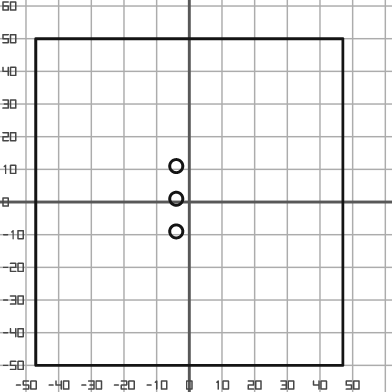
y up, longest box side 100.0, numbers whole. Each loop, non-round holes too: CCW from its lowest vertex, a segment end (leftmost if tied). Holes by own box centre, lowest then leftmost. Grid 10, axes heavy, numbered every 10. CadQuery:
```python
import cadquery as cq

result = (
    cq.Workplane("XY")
    .moveTo(-47.0, -50.0)
    .lineTo(47.0, -50.0)
    .lineTo(47.0, 50.0)
    .lineTo(-47.0, 50.0)
    .close()
    .moveTo(-4.0, -9.0)
    .circle(2.0)
    .moveTo(-4.0, 1.0)
    .circle(2.0)
    .moveTo(-4.0, 11.0)
    .circle(2.0)
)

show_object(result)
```